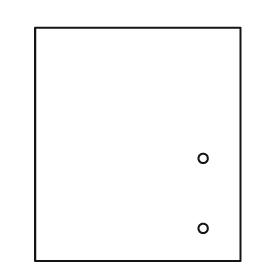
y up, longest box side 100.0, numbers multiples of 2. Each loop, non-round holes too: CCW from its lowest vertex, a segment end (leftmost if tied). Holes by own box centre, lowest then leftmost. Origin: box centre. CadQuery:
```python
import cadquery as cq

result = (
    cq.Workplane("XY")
    .moveTo(-44.0, -50.0)
    .lineTo(44.0, -50.0)
    .lineTo(44.0, 50.0)
    .lineTo(-44.0, 50.0)
    .close()
    .moveTo(28.0, -36.0)
    .circle(2.0)
    .moveTo(28.0, -6.0)
    .circle(2.0)
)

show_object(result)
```